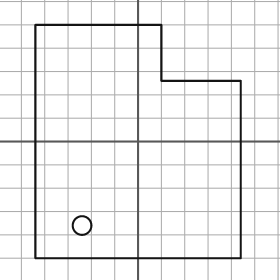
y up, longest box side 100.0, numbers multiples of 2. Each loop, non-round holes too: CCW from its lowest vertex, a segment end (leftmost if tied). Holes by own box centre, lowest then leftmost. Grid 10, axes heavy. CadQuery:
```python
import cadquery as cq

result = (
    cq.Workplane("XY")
    .moveTo(-44.0, -50.0)
    .lineTo(44.0, -50.0)
    .lineTo(44.0, 26.0)
    .lineTo(10.0, 26.0)
    .lineTo(10.0, 50.0)
    .lineTo(-44.0, 50.0)
    .close()
    .moveTo(-24.0, -36.0)
    .circle(4.0)
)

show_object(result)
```